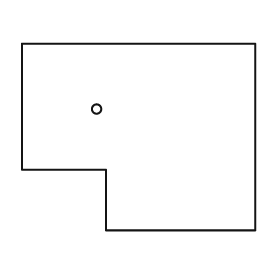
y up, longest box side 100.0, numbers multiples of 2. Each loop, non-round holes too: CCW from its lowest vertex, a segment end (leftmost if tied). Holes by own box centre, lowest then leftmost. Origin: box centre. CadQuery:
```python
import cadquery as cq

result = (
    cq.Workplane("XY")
    .moveTo(-14.0, -40.0)
    .lineTo(50.0, -40.0)
    .lineTo(50.0, 40.0)
    .lineTo(-50.0, 40.0)
    .lineTo(-50.0, -14.0)
    .lineTo(-14.0, -14.0)
    .close()
    .moveTo(-18.0, 12.0)
    .circle(2.0)
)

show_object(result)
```